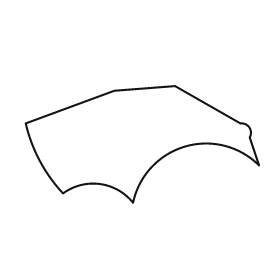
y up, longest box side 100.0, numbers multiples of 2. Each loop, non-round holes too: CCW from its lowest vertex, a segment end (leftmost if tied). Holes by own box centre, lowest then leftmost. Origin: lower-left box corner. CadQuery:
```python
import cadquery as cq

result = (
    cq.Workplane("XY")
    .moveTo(46.0, 0.0)
    .threePointArc((68.0, 24.0), (100.0, 16.0))
    .lineTo(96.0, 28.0)
    .threePointArc((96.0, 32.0), (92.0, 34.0))
    .lineTo(64.0, 50.0)
    .lineTo(38.0, 48.0)
    .lineTo(0.0, 34.0)
    .threePointArc((6.0, 18.0), (16.0, 4.0))
    .threePointArc((32.0, 8.0), (46.0, 0.0))
    .close()
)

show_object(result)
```